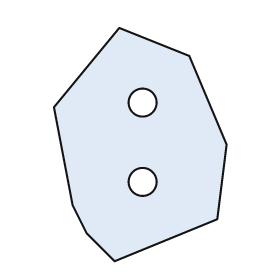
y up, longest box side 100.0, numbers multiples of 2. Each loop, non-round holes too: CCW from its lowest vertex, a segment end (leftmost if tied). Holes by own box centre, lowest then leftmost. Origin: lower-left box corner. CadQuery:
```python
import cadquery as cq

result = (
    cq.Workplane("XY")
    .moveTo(26.0, 0.0)
    .lineTo(70.0, 18.0)
    .lineTo(74.0, 50.0)
    .lineTo(58.0, 88.0)
    .lineTo(28.0, 100.0)
    .lineTo(0.0, 66.0)
    .lineTo(8.0, 24.0)
    .lineTo(14.0, 12.0)
    .close()
    .moveTo(38.0, 34.0)
    .circle(6.0)
    .moveTo(38.0, 68.0)
    .circle(6.0)
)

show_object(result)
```